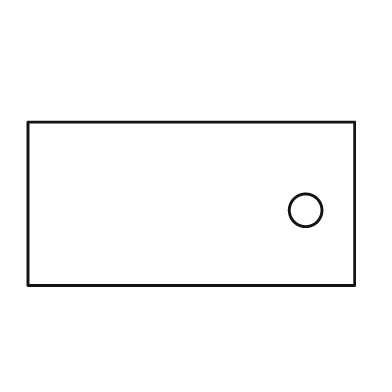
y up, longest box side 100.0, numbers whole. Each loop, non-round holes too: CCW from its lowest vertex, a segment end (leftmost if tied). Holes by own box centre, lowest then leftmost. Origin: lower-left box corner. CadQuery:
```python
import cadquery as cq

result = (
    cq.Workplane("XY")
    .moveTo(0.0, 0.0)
    .lineTo(100.0, 0.0)
    .lineTo(100.0, 50.0)
    .lineTo(0.0, 50.0)
    .close()
    .moveTo(85.0, 23.0)
    .circle(5.0)
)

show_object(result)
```